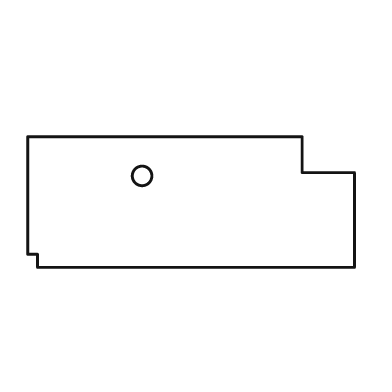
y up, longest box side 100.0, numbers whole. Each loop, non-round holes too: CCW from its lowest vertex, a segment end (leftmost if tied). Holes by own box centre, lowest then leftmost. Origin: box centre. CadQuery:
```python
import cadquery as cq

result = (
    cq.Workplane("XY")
    .moveTo(-47.0, -20.0)
    .lineTo(50.0, -20.0)
    .lineTo(50.0, 9.0)
    .lineTo(34.0, 9.0)
    .lineTo(34.0, 20.0)
    .lineTo(-50.0, 20.0)
    .lineTo(-50.0, -16.0)
    .lineTo(-47.0, -16.0)
    .close()
    .moveTo(-15.0, 8.0)
    .circle(3.0)
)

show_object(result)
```